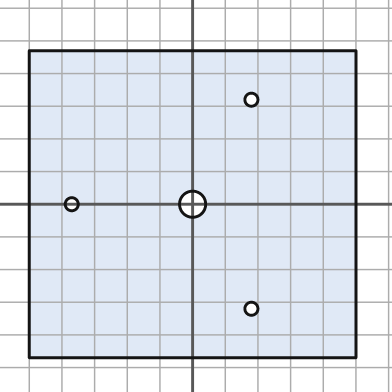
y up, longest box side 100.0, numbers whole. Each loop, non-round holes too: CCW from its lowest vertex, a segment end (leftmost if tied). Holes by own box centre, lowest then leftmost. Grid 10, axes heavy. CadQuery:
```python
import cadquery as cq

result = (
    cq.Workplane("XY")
    .moveTo(-50.0, -47.0)
    .lineTo(50.0, -47.0)
    .lineTo(50.0, 47.0)
    .lineTo(-50.0, 47.0)
    .close()
    .moveTo(18.0, -32.0)
    .circle(2.0)
    .moveTo(-37.0, 0.0)
    .circle(2.0)
    .moveTo(0.0, 0.0)
    .circle(4.0)
    .moveTo(18.0, 32.0)
    .circle(2.0)
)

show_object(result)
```